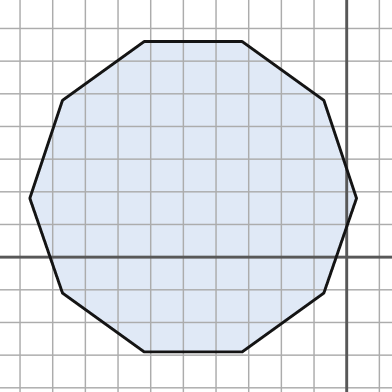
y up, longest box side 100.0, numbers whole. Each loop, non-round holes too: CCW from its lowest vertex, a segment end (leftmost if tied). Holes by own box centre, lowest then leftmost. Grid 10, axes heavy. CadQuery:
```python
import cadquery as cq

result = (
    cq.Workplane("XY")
    .moveTo(-62.0, -29.0)
    .lineTo(-32.0, -29.0)
    .lineTo(-7.0, -11.0)
    .lineTo(3.0, 18.0)
    .lineTo(-7.0, 48.0)
    .lineTo(-32.0, 66.0)
    .lineTo(-62.0, 66.0)
    .lineTo(-87.0, 48.0)
    .lineTo(-97.0, 18.0)
    .lineTo(-87.0, -11.0)
    .close()
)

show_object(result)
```